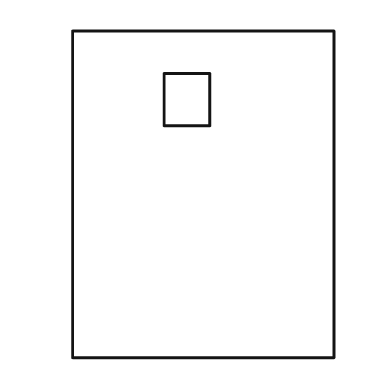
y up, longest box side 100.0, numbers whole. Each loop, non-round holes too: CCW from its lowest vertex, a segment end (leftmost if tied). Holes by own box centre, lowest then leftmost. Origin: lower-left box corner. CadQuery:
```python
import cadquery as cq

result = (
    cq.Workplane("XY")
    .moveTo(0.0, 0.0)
    .lineTo(80.0, 0.0)
    .lineTo(80.0, 100.0)
    .lineTo(0.0, 100.0)
    .close()
    .moveTo(28.0, 71.0)
    .lineTo(42.0, 71.0)
    .lineTo(42.0, 87.0)
    .lineTo(28.0, 87.0)
    .close()
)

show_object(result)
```